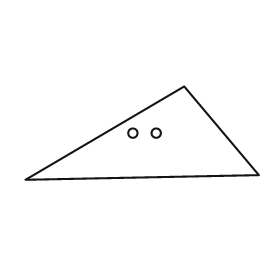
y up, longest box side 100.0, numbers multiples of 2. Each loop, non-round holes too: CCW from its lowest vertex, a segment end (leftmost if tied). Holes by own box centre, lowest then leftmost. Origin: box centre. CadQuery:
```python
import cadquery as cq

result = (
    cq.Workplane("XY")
    .moveTo(-50.0, -20.0)
    .lineTo(50.0, -18.0)
    .lineTo(18.0, 20.0)
    .close()
    .moveTo(-4.0, 0.0)
    .circle(2.0)
    .moveTo(6.0, 0.0)
    .circle(2.0)
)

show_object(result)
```